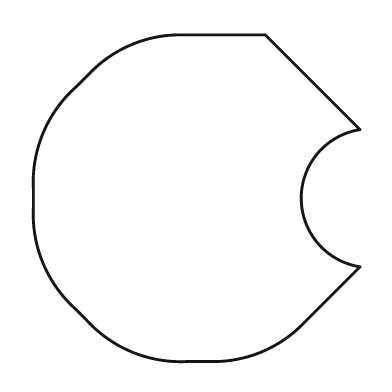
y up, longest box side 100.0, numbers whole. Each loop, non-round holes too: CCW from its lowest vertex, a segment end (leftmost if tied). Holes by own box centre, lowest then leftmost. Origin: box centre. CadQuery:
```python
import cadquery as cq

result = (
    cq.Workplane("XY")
    .moveTo(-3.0, -50.0)
    .lineTo(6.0, -50.0)
    .threePointArc((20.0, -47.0), (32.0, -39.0))
    .lineTo(50.0, -21.0)
    .threePointArc((32.0, 0.0), (50.0, 21.0))
    .lineTo(21.0, 50.0)
    .lineTo(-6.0, 50.0)
    .threePointArc((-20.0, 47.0), (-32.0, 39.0))
    .lineTo(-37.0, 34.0)
    .threePointArc((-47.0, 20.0), (-50.0, 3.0))
    .lineTo(-50.0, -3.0)
    .threePointArc((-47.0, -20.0), (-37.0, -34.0))
    .lineTo(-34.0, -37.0)
    .threePointArc((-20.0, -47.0), (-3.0, -50.0))
    .close()
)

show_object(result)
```